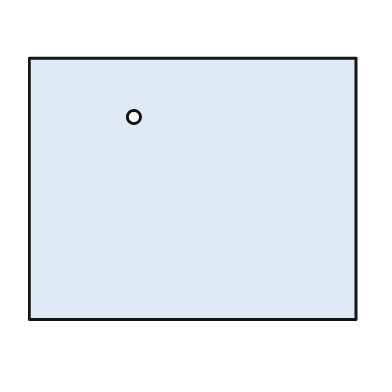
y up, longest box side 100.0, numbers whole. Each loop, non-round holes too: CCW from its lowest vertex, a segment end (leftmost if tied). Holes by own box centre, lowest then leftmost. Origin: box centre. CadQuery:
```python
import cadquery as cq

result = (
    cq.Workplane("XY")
    .moveTo(-50.0, -40.0)
    .lineTo(50.0, -40.0)
    .lineTo(50.0, 40.0)
    .lineTo(-50.0, 40.0)
    .close()
    .moveTo(-18.0, 22.0)
    .circle(2.0)
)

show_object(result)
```